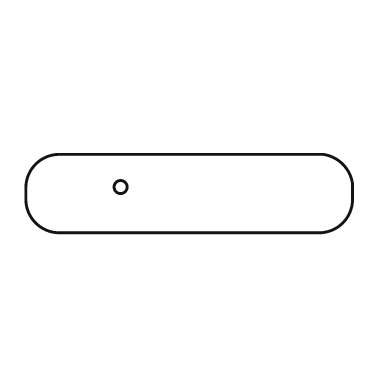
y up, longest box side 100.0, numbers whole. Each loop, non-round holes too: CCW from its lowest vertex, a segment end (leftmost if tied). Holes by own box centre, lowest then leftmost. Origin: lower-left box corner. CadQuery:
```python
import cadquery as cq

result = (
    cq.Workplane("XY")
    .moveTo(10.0, 0.0)
    .lineTo(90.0, 0.0)
    .threePointArc((97.0, 3.0), (100.0, 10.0))
    .lineTo(100.0, 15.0)
    .threePointArc((97.0, 21.0), (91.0, 24.0))
    .lineTo(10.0, 24.0)
    .threePointArc((3.0, 21.0), (0.0, 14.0))
    .lineTo(0.0, 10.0)
    .threePointArc((3.0, 3.0), (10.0, 0.0))
    .close()
    .moveTo(29.0, 14.0)
    .circle(2.0)
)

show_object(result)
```